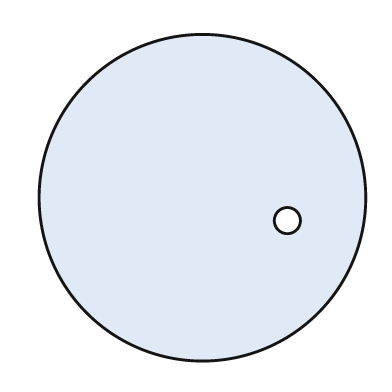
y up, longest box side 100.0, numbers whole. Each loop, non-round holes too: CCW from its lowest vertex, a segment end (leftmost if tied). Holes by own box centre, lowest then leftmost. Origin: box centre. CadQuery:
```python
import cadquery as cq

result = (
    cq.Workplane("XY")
    .moveTo(0.0, 0.0)
    .circle(50.0)
    .moveTo(26.0, -7.0)
    .circle(4.0)
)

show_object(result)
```